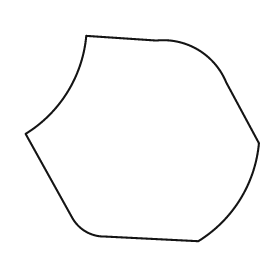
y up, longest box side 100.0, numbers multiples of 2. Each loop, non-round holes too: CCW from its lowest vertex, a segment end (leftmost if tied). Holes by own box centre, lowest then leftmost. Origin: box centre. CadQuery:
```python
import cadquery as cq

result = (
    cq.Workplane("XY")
    .moveTo(24.0, -44.0)
    .threePointArc((42.0, -26.0), (50.0, -2.0))
    .lineTo(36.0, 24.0)
    .threePointArc((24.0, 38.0), (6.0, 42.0))
    .lineTo(-24.0, 44.0)
    .threePointArc((-32.0, 20.0), (-50.0, 2.0))
    .lineTo(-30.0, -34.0)
    .threePointArc((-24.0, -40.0), (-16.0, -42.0))
    .close()
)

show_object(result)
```